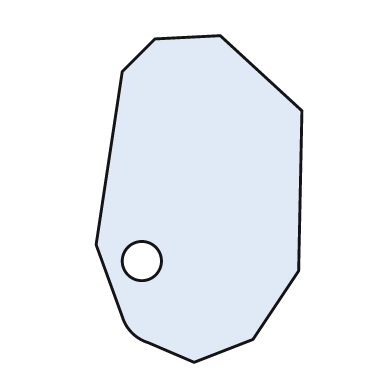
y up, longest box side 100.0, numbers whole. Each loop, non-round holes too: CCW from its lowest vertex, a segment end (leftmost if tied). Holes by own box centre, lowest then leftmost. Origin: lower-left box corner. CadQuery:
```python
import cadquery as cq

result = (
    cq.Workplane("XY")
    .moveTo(30.0, 0.0)
    .lineTo(48.0, 7.0)
    .lineTo(62.0, 28.0)
    .lineTo(63.0, 77.0)
    .lineTo(38.0, 100.0)
    .lineTo(18.0, 99.0)
    .lineTo(8.0, 89.0)
    .lineTo(0.0, 36.0)
    .lineTo(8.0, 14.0)
    .threePointArc((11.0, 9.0), (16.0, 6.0))
    .close()
    .moveTo(14.0, 31.0)
    .circle(6.0)
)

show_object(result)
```